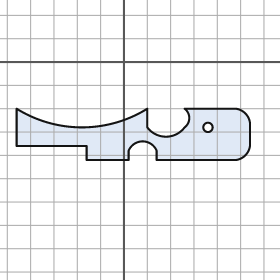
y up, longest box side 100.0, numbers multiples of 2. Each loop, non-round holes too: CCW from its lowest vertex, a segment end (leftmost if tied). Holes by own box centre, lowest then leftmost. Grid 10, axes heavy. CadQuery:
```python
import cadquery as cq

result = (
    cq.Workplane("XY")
    .moveTo(-16.0, -42.0)
    .lineTo(2.0, -42.0)
    .lineTo(2.0, -38.0)
    .threePointArc((8.0, -34.0), (14.0, -38.0))
    .lineTo(14.0, -42.0)
    .lineTo(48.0, -42.0)
    .threePointArc((52.0, -40.0), (54.0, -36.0))
    .lineTo(54.0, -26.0)
    .threePointArc((52.0, -22.0), (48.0, -20.0))
    .lineTo(26.0, -20.0)
    .threePointArc((28.0, -24.0), (26.0, -28.0))
    .threePointArc((18.0, -32.0), (10.0, -28.0))
    .lineTo(10.0, -20.0)
    .threePointArc((-18.0, -28.0), (-46.0, -20.0))
    .lineTo(-46.0, -36.0)
    .lineTo(-16.0, -36.0)
    .close()
    .moveTo(36.0, -28.0)
    .circle(2.0)
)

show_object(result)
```